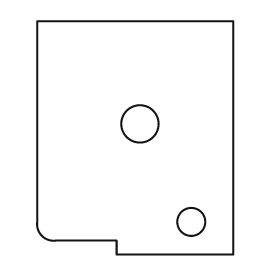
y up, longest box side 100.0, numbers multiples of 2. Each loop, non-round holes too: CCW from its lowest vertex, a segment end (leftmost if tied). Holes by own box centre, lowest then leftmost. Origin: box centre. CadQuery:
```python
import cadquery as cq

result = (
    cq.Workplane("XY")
    .moveTo(-8.0, -50.0)
    .lineTo(42.0, -50.0)
    .lineTo(42.0, 50.0)
    .lineTo(-42.0, 50.0)
    .lineTo(-42.0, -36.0)
    .threePointArc((-40.0, -42.0), (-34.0, -44.0))
    .lineTo(-8.0, -44.0)
    .close()
    .moveTo(24.0, -36.0)
    .circle(6.0)
    .moveTo(2.0, 6.0)
    .circle(8.0)
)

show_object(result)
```